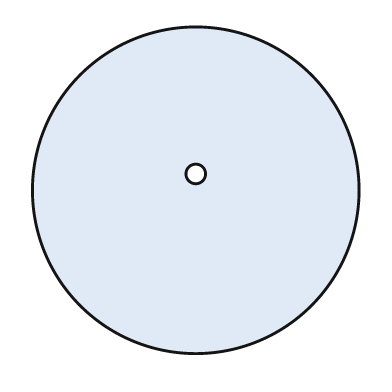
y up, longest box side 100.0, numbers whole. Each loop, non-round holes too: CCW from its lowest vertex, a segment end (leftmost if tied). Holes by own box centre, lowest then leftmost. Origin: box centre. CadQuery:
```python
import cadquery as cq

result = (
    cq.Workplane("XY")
    .moveTo(0.0, 0.0)
    .circle(50.0)
    .moveTo(0.0, 5.0)
    .circle(3.0)
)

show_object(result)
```